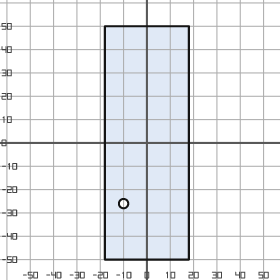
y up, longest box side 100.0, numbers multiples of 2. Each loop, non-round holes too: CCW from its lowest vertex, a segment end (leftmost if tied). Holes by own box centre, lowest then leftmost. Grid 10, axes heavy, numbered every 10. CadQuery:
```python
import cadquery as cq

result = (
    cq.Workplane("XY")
    .moveTo(-18.0, -50.0)
    .lineTo(18.0, -50.0)
    .lineTo(18.0, 50.0)
    .lineTo(-18.0, 50.0)
    .close()
    .moveTo(-10.0, -26.0)
    .circle(2.0)
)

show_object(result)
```